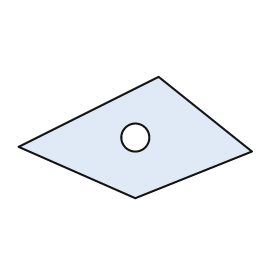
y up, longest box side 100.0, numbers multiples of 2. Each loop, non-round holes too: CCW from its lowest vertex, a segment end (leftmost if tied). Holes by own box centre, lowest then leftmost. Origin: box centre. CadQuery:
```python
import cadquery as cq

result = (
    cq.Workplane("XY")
    .moveTo(0.0, -26.0)
    .lineTo(50.0, -6.0)
    .lineTo(10.0, 26.0)
    .lineTo(-50.0, -4.0)
    .close()
    .moveTo(0.0, 0.0)
    .circle(6.0)
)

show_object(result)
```